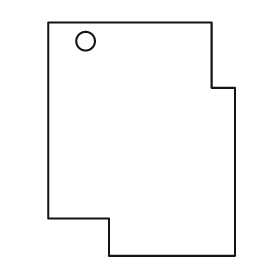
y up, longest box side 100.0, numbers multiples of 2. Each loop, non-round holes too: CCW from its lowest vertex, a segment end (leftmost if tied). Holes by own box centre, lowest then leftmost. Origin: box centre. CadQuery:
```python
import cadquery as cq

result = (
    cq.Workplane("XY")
    .moveTo(-14.0, -50.0)
    .lineTo(40.0, -50.0)
    .lineTo(40.0, 22.0)
    .lineTo(30.0, 22.0)
    .lineTo(30.0, 50.0)
    .lineTo(-40.0, 50.0)
    .lineTo(-40.0, -34.0)
    .lineTo(-14.0, -34.0)
    .close()
    .moveTo(-24.0, 42.0)
    .circle(4.0)
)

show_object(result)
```